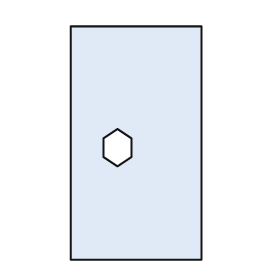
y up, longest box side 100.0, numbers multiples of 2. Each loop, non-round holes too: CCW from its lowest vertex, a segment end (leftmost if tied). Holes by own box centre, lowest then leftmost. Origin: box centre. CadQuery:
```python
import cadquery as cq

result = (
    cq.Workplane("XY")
    .moveTo(-28.0, -50.0)
    .lineTo(28.0, -50.0)
    .lineTo(28.0, 50.0)
    .lineTo(-28.0, 50.0)
    .close()
    .moveTo(-8.0, -10.0)
    .lineTo(-2.0, -6.0)
    .lineTo(-2.0, 2.0)
    .lineTo(-8.0, 6.0)
    .lineTo(-14.0, 2.0)
    .lineTo(-14.0, -6.0)
    .close()
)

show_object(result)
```